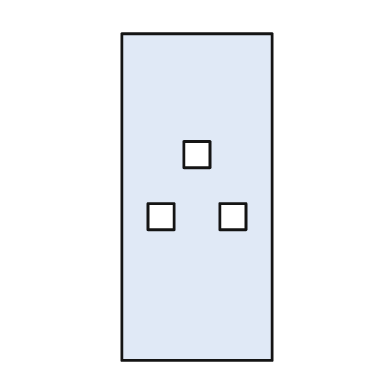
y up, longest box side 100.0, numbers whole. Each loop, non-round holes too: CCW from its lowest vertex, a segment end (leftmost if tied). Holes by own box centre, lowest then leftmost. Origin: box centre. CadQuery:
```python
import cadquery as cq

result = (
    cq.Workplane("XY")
    .moveTo(-23.0, -50.0)
    .lineTo(23.0, -50.0)
    .lineTo(23.0, 50.0)
    .lineTo(-23.0, 50.0)
    .close()
    .moveTo(-15.0, -10.0)
    .lineTo(-7.0, -10.0)
    .lineTo(-7.0, -2.0)
    .lineTo(-15.0, -2.0)
    .close()
    .moveTo(7.0, -10.0)
    .lineTo(15.0, -10.0)
    .lineTo(15.0, -2.0)
    .lineTo(7.0, -2.0)
    .close()
    .moveTo(-4.0, 9.0)
    .lineTo(4.0, 9.0)
    .lineTo(4.0, 17.0)
    .lineTo(-4.0, 17.0)
    .close()
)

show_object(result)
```